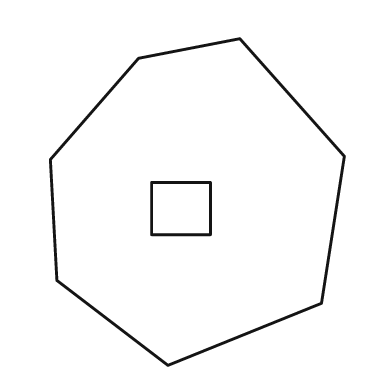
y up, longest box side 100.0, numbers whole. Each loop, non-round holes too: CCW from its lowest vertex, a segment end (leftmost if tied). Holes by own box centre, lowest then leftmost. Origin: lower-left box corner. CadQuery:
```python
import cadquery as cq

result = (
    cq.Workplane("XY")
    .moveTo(36.0, 0.0)
    .lineTo(83.0, 19.0)
    .lineTo(90.0, 64.0)
    .lineTo(58.0, 100.0)
    .lineTo(27.0, 94.0)
    .lineTo(0.0, 63.0)
    .lineTo(2.0, 26.0)
    .close()
    .moveTo(31.0, 40.0)
    .lineTo(49.0, 40.0)
    .lineTo(49.0, 56.0)
    .lineTo(31.0, 56.0)
    .close()
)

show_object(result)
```